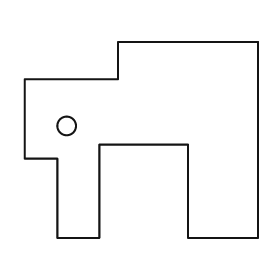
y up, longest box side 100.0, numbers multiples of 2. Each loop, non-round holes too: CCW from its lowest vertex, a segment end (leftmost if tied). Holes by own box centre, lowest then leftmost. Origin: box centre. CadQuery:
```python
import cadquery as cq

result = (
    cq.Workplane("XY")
    .moveTo(-36.0, -42.0)
    .lineTo(-18.0, -42.0)
    .lineTo(-18.0, -2.0)
    .lineTo(20.0, -2.0)
    .lineTo(20.0, -42.0)
    .lineTo(50.0, -42.0)
    .lineTo(50.0, 42.0)
    .lineTo(-10.0, 42.0)
    .lineTo(-10.0, 26.0)
    .lineTo(-50.0, 26.0)
    .lineTo(-50.0, -8.0)
    .lineTo(-36.0, -8.0)
    .close()
    .moveTo(-32.0, 6.0)
    .circle(4.0)
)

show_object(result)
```